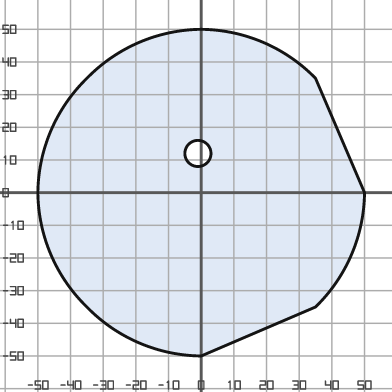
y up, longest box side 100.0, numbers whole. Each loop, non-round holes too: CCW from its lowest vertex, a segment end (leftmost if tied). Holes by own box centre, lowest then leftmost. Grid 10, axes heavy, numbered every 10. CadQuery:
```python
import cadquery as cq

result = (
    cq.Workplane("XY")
    .moveTo(0.0, -50.0)
    .lineTo(35.0, -35.0)
    .threePointArc((46.0, -19.0), (50.0, 0.0))
    .lineTo(35.0, 35.0)
    .threePointArc((19.0, 46.0), (0.0, 50.0))
    .threePointArc((-19.0, 46.0), (-35.0, 35.0))
    .threePointArc((-46.0, 19.0), (-50.0, 0.0))
    .threePointArc((-46.0, -19.0), (-35.0, -35.0))
    .threePointArc((-19.0, -46.0), (0.0, -50.0))
    .close()
    .moveTo(-1.0, 12.0)
    .circle(4.0)
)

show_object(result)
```